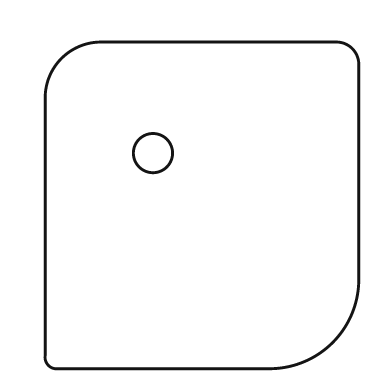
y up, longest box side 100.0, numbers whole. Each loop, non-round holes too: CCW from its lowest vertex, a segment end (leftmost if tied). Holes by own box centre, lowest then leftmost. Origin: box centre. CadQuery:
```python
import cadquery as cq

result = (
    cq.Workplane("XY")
    .moveTo(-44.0, -50.0)
    .lineTo(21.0, -50.0)
    .threePointArc((40.0, -42.0), (48.0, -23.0))
    .lineTo(48.0, 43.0)
    .threePointArc((46.0, 48.0), (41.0, 50.0))
    .lineTo(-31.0, 50.0)
    .threePointArc((-43.0, 45.0), (-48.0, 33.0))
    .lineTo(-48.0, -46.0)
    .threePointArc((-47.0, -49.0), (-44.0, -50.0))
    .close()
    .moveTo(-15.0, 16.0)
    .circle(6.0)
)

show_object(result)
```